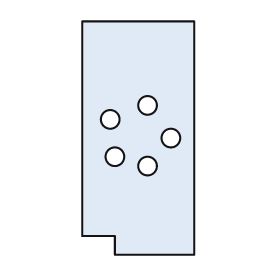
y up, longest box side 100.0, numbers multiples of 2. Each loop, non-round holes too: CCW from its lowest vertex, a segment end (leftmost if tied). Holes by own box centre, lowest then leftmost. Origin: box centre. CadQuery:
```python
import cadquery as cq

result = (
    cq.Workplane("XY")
    .moveTo(-10.0, -50.0)
    .lineTo(24.0, -50.0)
    .lineTo(24.0, 50.0)
    .lineTo(-24.0, 50.0)
    .lineTo(-24.0, -42.0)
    .lineTo(-10.0, -42.0)
    .close()
    .moveTo(4.0, -12.0)
    .circle(4.0)
    .moveTo(-10.0, -8.0)
    .circle(4.0)
    .moveTo(14.0, 0.0)
    .circle(4.0)
    .moveTo(-12.0, 8.0)
    .circle(4.0)
    .moveTo(4.0, 14.0)
    .circle(4.0)
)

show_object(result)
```